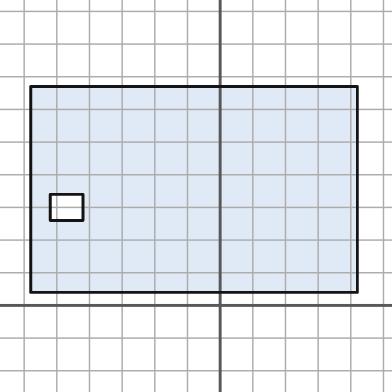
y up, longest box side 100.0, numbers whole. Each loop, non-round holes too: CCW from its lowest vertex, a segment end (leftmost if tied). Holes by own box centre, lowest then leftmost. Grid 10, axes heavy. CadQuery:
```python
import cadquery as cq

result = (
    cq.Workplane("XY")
    .moveTo(-58.0, 4.0)
    .lineTo(42.0, 4.0)
    .lineTo(42.0, 67.0)
    .lineTo(-58.0, 67.0)
    .close()
    .moveTo(-52.0, 26.0)
    .lineTo(-42.0, 26.0)
    .lineTo(-42.0, 34.0)
    .lineTo(-52.0, 34.0)
    .close()
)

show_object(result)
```